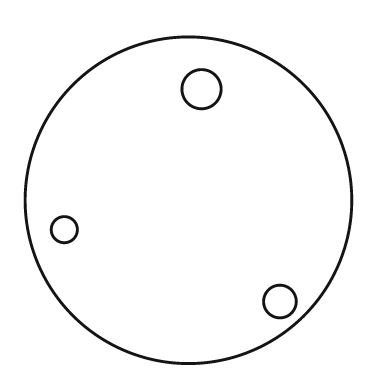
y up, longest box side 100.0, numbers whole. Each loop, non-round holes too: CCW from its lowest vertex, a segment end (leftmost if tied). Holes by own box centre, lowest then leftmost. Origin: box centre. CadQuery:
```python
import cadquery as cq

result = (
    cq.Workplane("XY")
    .moveTo(0.0, 0.0)
    .circle(50.0)
    .moveTo(28.0, -31.0)
    .circle(5.0)
    .moveTo(-38.0, -9.0)
    .circle(4.0)
    .moveTo(4.0, 34.0)
    .circle(6.0)
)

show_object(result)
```